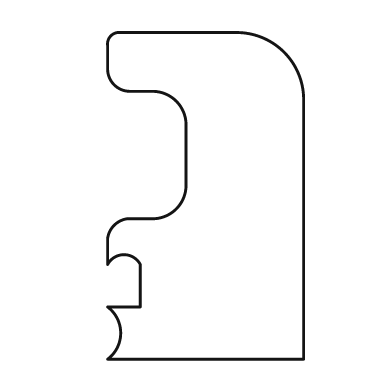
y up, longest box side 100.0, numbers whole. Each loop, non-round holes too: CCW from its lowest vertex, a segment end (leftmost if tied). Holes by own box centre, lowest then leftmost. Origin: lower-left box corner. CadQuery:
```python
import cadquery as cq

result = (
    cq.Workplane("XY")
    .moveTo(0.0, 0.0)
    .lineTo(60.0, 0.0)
    .lineTo(60.0, 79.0)
    .threePointArc((54.0, 94.0), (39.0, 100.0))
    .lineTo(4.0, 100.0)
    .threePointArc((1.0, 99.0), (0.0, 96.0))
    .lineTo(0.0, 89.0)
    .threePointArc((2.0, 84.0), (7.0, 82.0))
    .lineTo(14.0, 82.0)
    .threePointArc((21.0, 79.0), (24.0, 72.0))
    .lineTo(24.0, 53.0)
    .threePointArc((21.0, 46.0), (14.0, 43.0))
    .lineTo(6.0, 43.0)
    .threePointArc((2.0, 41.0), (0.0, 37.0))
    .lineTo(0.0, 29.0)
    .threePointArc((5.0, 32.0), (10.0, 29.0))
    .lineTo(10.0, 16.0)
    .lineTo(0.0, 16.0)
    .threePointArc((4.0, 8.0), (0.0, 0.0))
    .close()
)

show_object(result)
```